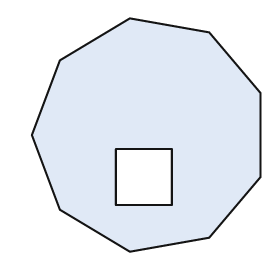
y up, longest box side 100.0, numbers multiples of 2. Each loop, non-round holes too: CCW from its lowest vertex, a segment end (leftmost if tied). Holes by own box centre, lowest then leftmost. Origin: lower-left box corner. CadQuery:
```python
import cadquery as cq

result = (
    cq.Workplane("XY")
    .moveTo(42.0, 0.0)
    .lineTo(76.0, 6.0)
    .lineTo(98.0, 32.0)
    .lineTo(98.0, 68.0)
    .lineTo(76.0, 94.0)
    .lineTo(42.0, 100.0)
    .lineTo(12.0, 82.0)
    .lineTo(0.0, 50.0)
    .lineTo(12.0, 18.0)
    .close()
    .moveTo(36.0, 20.0)
    .lineTo(60.0, 20.0)
    .lineTo(60.0, 44.0)
    .lineTo(36.0, 44.0)
    .close()
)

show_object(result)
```